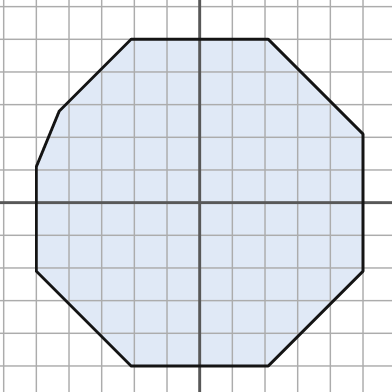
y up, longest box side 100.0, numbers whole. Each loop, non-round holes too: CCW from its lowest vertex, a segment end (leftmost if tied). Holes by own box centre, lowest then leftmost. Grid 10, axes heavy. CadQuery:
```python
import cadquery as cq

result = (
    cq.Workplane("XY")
    .moveTo(-21.0, -50.0)
    .lineTo(21.0, -50.0)
    .lineTo(50.0, -21.0)
    .lineTo(50.0, 21.0)
    .lineTo(21.0, 50.0)
    .lineTo(-21.0, 50.0)
    .lineTo(-43.0, 28.0)
    .lineTo(-50.0, 11.0)
    .lineTo(-50.0, -21.0)
    .close()
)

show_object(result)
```